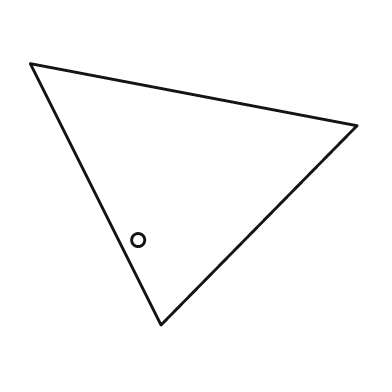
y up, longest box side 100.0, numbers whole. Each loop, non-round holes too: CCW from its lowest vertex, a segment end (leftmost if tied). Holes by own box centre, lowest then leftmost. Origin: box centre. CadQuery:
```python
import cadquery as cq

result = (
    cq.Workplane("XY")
    .moveTo(-10.0, -40.0)
    .lineTo(50.0, 21.0)
    .lineTo(-50.0, 40.0)
    .close()
    .moveTo(-17.0, -14.0)
    .circle(2.0)
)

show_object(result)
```